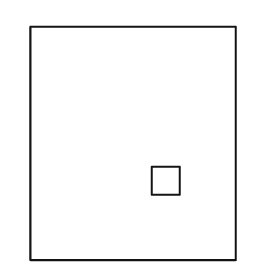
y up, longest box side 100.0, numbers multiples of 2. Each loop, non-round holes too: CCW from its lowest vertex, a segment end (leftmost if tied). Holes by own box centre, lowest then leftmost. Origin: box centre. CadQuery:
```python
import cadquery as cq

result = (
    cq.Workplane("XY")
    .moveTo(-44.0, -50.0)
    .lineTo(44.0, -50.0)
    .lineTo(44.0, 50.0)
    .lineTo(-44.0, 50.0)
    .close()
    .moveTo(8.0, -22.0)
    .lineTo(20.0, -22.0)
    .lineTo(20.0, -10.0)
    .lineTo(8.0, -10.0)
    .close()
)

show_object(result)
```